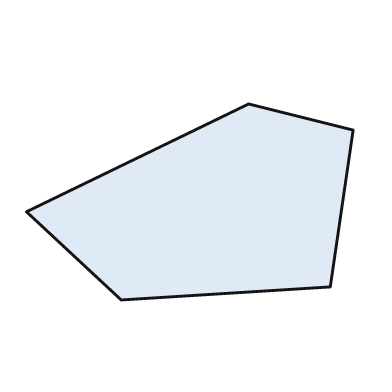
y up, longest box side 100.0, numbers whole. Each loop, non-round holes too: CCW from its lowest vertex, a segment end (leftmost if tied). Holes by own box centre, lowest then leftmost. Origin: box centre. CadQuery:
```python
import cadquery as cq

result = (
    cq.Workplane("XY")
    .moveTo(-21.0, -30.0)
    .lineTo(43.0, -26.0)
    .lineTo(50.0, 22.0)
    .lineTo(18.0, 30.0)
    .lineTo(-50.0, -3.0)
    .close()
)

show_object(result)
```